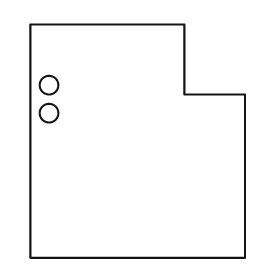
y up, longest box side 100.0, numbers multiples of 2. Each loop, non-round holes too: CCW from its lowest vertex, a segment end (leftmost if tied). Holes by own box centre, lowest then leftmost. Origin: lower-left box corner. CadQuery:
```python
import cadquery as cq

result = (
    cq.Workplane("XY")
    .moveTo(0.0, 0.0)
    .lineTo(92.0, 0.0)
    .lineTo(92.0, 70.0)
    .lineTo(66.0, 70.0)
    .lineTo(66.0, 100.0)
    .lineTo(0.0, 100.0)
    .close()
    .moveTo(8.0, 62.0)
    .circle(4.0)
    .moveTo(8.0, 74.0)
    .circle(4.0)
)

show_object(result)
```